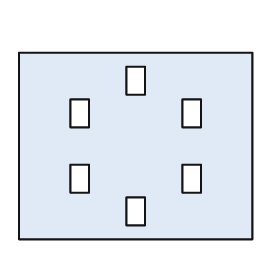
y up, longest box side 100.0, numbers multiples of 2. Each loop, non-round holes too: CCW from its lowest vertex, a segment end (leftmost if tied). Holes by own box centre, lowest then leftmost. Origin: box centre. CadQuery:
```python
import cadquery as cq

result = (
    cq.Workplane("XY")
    .moveTo(-50.0, -40.0)
    .lineTo(50.0, -40.0)
    .lineTo(50.0, 40.0)
    .lineTo(-50.0, 40.0)
    .close()
    .moveTo(-4.0, -34.0)
    .lineTo(4.0, -34.0)
    .lineTo(4.0, -22.0)
    .lineTo(-4.0, -22.0)
    .close()
    .moveTo(-28.0, -20.0)
    .lineTo(-20.0, -20.0)
    .lineTo(-20.0, -8.0)
    .lineTo(-28.0, -8.0)
    .close()
    .moveTo(20.0, -20.0)
    .lineTo(28.0, -20.0)
    .lineTo(28.0, -8.0)
    .lineTo(20.0, -8.0)
    .close()
    .moveTo(-28.0, 8.0)
    .lineTo(-20.0, 8.0)
    .lineTo(-20.0, 20.0)
    .lineTo(-28.0, 20.0)
    .close()
    .moveTo(20.0, 8.0)
    .lineTo(28.0, 8.0)
    .lineTo(28.0, 20.0)
    .lineTo(20.0, 20.0)
    .close()
    .moveTo(-4.0, 22.0)
    .lineTo(4.0, 22.0)
    .lineTo(4.0, 34.0)
    .lineTo(-4.0, 34.0)
    .close()
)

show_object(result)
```